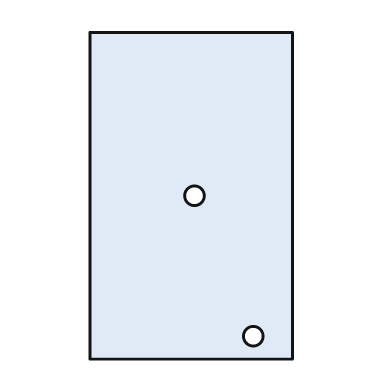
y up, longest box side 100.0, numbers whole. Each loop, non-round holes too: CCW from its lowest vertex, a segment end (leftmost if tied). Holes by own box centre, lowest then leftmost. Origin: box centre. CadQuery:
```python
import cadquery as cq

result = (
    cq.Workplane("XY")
    .moveTo(-31.0, -50.0)
    .lineTo(31.0, -50.0)
    .lineTo(31.0, 50.0)
    .lineTo(-31.0, 50.0)
    .close()
    .moveTo(19.0, -43.0)
    .circle(3.0)
    .moveTo(1.0, 0.0)
    .circle(3.0)
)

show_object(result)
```